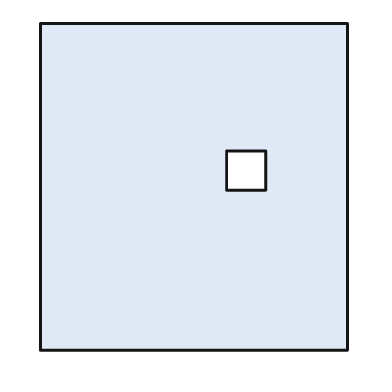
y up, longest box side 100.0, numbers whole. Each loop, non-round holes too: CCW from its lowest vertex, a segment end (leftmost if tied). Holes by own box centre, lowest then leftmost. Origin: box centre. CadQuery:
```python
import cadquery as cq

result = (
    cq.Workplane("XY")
    .moveTo(-47.0, -50.0)
    .lineTo(47.0, -50.0)
    .lineTo(47.0, 50.0)
    .lineTo(-47.0, 50.0)
    .close()
    .moveTo(10.0, -1.0)
    .lineTo(22.0, -1.0)
    .lineTo(22.0, 11.0)
    .lineTo(10.0, 11.0)
    .close()
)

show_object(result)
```